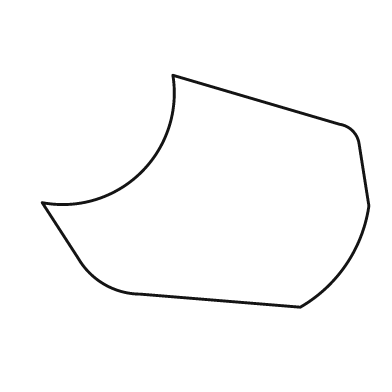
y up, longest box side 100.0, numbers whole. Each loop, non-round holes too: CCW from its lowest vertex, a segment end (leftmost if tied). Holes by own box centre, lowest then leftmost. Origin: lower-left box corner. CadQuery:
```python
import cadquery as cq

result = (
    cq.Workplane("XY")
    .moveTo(79.0, 0.0)
    .threePointArc((93.0, 13.0), (100.0, 31.0))
    .lineTo(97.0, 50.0)
    .threePointArc((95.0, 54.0), (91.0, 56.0))
    .lineTo(40.0, 71.0)
    .threePointArc((30.0, 41.0), (0.0, 32.0))
    .lineTo(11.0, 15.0)
    .threePointArc((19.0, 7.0), (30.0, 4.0))
    .close()
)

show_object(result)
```